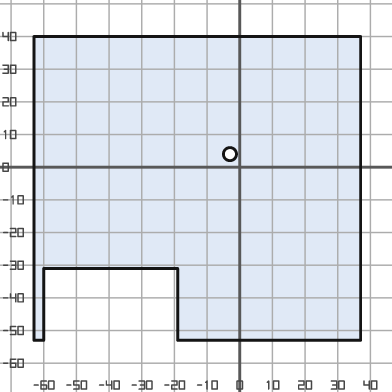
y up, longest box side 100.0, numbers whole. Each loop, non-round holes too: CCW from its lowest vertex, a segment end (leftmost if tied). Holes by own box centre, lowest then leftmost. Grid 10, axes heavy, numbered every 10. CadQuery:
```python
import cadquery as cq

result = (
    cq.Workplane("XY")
    .moveTo(-63.0, -53.0)
    .lineTo(-60.0, -53.0)
    .lineTo(-60.0, -31.0)
    .lineTo(-19.0, -31.0)
    .lineTo(-19.0, -53.0)
    .lineTo(37.0, -53.0)
    .lineTo(37.0, 40.0)
    .lineTo(-63.0, 40.0)
    .close()
    .moveTo(-3.0, 4.0)
    .circle(2.0)
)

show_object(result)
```